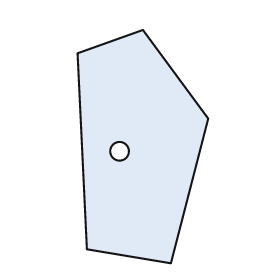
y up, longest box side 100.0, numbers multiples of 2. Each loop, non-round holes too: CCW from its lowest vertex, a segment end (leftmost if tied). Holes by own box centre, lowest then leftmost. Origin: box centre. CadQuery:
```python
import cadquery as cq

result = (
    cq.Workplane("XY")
    .moveTo(12.0, -50.0)
    .lineTo(28.0, 12.0)
    .lineTo(0.0, 50.0)
    .lineTo(-28.0, 40.0)
    .lineTo(-24.0, -44.0)
    .close()
    .moveTo(-10.0, -2.0)
    .circle(4.0)
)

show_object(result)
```